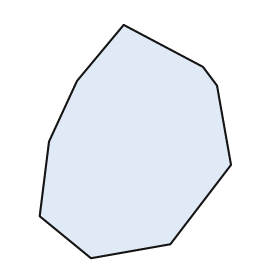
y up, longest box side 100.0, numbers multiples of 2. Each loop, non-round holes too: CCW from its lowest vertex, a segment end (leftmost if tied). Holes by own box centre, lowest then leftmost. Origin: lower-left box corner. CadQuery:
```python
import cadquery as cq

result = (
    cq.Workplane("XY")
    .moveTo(22.0, 0.0)
    .lineTo(56.0, 6.0)
    .lineTo(82.0, 40.0)
    .lineTo(76.0, 74.0)
    .lineTo(70.0, 82.0)
    .lineTo(36.0, 100.0)
    .lineTo(16.0, 76.0)
    .lineTo(4.0, 50.0)
    .lineTo(0.0, 18.0)
    .close()
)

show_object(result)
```